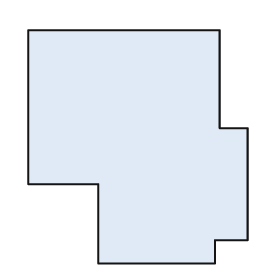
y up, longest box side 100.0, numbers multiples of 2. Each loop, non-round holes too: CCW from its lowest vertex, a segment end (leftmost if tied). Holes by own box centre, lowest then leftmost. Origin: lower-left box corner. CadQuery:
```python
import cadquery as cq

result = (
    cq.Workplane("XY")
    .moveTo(30.0, 0.0)
    .lineTo(80.0, 0.0)
    .lineTo(80.0, 10.0)
    .lineTo(94.0, 10.0)
    .lineTo(94.0, 58.0)
    .lineTo(82.0, 58.0)
    .lineTo(82.0, 100.0)
    .lineTo(0.0, 100.0)
    .lineTo(0.0, 34.0)
    .lineTo(30.0, 34.0)
    .close()
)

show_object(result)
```